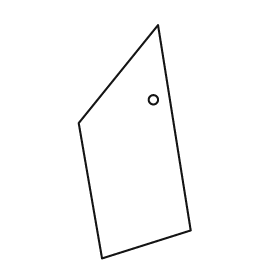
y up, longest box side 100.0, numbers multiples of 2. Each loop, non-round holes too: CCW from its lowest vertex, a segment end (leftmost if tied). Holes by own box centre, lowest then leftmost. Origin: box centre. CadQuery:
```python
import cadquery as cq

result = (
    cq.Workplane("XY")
    .moveTo(-14.0, -50.0)
    .lineTo(24.0, -38.0)
    .lineTo(10.0, 50.0)
    .lineTo(-24.0, 8.0)
    .close()
    .moveTo(8.0, 18.0)
    .circle(2.0)
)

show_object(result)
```